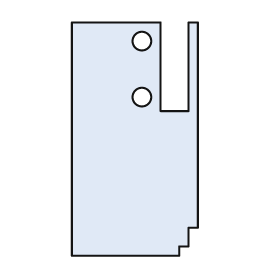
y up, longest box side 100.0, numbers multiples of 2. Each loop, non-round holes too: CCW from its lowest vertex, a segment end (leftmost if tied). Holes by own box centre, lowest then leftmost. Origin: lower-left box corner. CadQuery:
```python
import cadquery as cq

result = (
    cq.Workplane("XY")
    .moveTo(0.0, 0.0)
    .lineTo(46.0, 0.0)
    .lineTo(46.0, 4.0)
    .lineTo(50.0, 4.0)
    .lineTo(50.0, 12.0)
    .lineTo(54.0, 12.0)
    .lineTo(54.0, 100.0)
    .lineTo(50.0, 100.0)
    .lineTo(50.0, 62.0)
    .lineTo(38.0, 62.0)
    .lineTo(38.0, 100.0)
    .lineTo(0.0, 100.0)
    .close()
    .moveTo(30.0, 68.0)
    .circle(4.0)
    .moveTo(30.0, 92.0)
    .circle(4.0)
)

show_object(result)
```